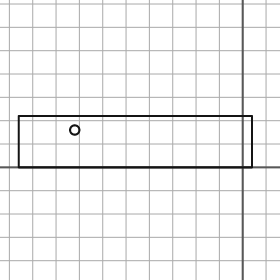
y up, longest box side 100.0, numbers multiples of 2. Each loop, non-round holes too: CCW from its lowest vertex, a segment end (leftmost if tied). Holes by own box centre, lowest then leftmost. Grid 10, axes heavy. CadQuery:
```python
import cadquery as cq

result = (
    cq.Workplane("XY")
    .moveTo(-96.0, 0.0)
    .lineTo(4.0, 0.0)
    .lineTo(4.0, 22.0)
    .lineTo(-96.0, 22.0)
    .close()
    .moveTo(-72.0, 16.0)
    .circle(2.0)
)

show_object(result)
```